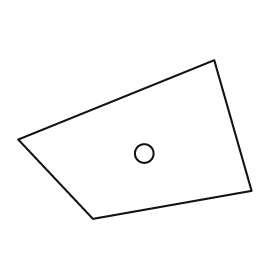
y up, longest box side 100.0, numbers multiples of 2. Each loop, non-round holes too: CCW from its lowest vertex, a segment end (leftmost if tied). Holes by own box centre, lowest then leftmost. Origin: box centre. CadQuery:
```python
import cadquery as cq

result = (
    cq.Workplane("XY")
    .moveTo(-18.0, -34.0)
    .lineTo(50.0, -22.0)
    .lineTo(34.0, 34.0)
    .lineTo(-50.0, 0.0)
    .close()
    .moveTo(4.0, -6.0)
    .circle(4.0)
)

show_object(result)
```